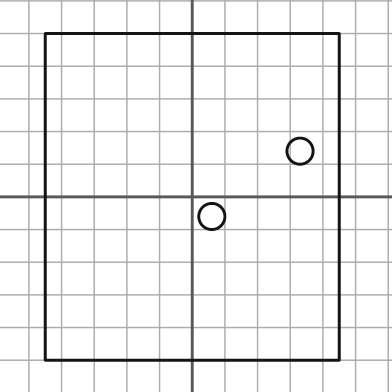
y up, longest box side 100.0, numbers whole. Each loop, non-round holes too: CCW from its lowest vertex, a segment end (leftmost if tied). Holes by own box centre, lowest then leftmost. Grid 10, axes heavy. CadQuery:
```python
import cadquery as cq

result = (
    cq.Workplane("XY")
    .moveTo(-45.0, -50.0)
    .lineTo(45.0, -50.0)
    .lineTo(45.0, 50.0)
    .lineTo(-45.0, 50.0)
    .close()
    .moveTo(6.0, -6.0)
    .circle(4.0)
    .moveTo(33.0, 14.0)
    .circle(4.0)
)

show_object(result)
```